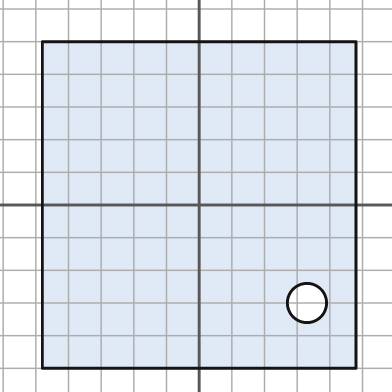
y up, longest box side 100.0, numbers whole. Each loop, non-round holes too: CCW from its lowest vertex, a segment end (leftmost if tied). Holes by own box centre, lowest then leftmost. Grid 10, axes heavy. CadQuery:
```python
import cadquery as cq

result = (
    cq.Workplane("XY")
    .moveTo(-48.0, -50.0)
    .lineTo(48.0, -50.0)
    .lineTo(48.0, 50.0)
    .lineTo(-48.0, 50.0)
    .close()
    .moveTo(33.0, -30.0)
    .circle(6.0)
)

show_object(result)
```